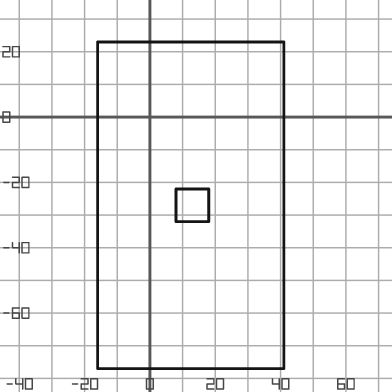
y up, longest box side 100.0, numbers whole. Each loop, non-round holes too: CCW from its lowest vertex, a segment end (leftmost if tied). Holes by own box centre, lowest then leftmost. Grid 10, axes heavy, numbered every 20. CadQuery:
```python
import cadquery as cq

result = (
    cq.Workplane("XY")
    .moveTo(-16.0, -77.0)
    .lineTo(41.0, -77.0)
    .lineTo(41.0, 23.0)
    .lineTo(-16.0, 23.0)
    .close()
    .moveTo(8.0, -32.0)
    .lineTo(18.0, -32.0)
    .lineTo(18.0, -22.0)
    .lineTo(8.0, -22.0)
    .close()
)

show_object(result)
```